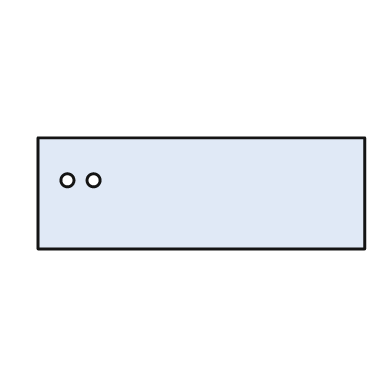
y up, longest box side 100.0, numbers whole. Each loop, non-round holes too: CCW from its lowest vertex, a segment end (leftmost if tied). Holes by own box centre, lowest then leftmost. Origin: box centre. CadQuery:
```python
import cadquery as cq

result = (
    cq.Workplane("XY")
    .moveTo(-50.0, -17.0)
    .lineTo(50.0, -17.0)
    .lineTo(50.0, 17.0)
    .lineTo(-50.0, 17.0)
    .close()
    .moveTo(-41.0, 4.0)
    .circle(2.0)
    .moveTo(-33.0, 4.0)
    .circle(2.0)
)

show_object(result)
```